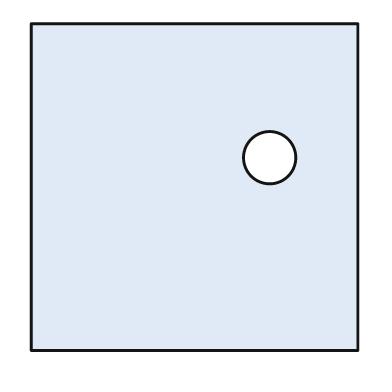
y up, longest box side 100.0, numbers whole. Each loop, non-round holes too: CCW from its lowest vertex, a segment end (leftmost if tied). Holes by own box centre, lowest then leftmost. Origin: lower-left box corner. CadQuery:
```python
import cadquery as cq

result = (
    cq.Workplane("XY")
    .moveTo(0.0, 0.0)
    .lineTo(100.0, 0.0)
    .lineTo(100.0, 100.0)
    .lineTo(0.0, 100.0)
    .close()
    .moveTo(73.0, 59.0)
    .circle(8.0)
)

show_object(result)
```